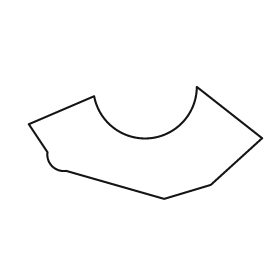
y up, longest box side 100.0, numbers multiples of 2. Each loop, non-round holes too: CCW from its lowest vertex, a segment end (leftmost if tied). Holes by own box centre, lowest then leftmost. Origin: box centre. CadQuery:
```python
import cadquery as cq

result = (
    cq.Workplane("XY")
    .moveTo(8.0, -24.0)
    .lineTo(28.0, -18.0)
    .lineTo(50.0, 2.0)
    .lineTo(22.0, 24.0)
    .threePointArc((2.0, 2.0), (-22.0, 20.0))
    .lineTo(-50.0, 8.0)
    .lineTo(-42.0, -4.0)
    .threePointArc((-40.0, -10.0), (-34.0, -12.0))
    .close()
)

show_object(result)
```